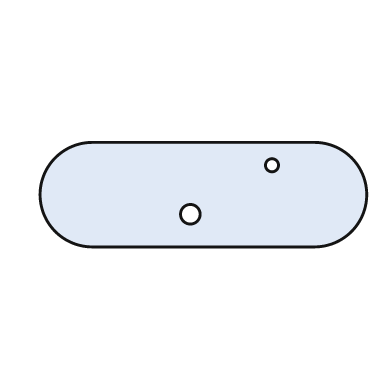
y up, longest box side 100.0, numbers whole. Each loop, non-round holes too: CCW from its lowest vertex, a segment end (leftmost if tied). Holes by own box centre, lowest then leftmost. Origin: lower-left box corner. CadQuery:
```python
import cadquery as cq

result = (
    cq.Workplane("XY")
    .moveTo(16.0, 0.0)
    .lineTo(84.0, 0.0)
    .threePointArc((100.0, 16.0), (84.0, 32.0))
    .lineTo(16.0, 32.0)
    .threePointArc((0.0, 16.0), (16.0, 0.0))
    .close()
    .moveTo(46.0, 10.0)
    .circle(3.0)
    .moveTo(71.0, 25.0)
    .circle(2.0)
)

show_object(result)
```